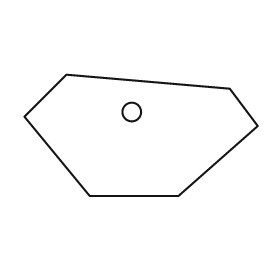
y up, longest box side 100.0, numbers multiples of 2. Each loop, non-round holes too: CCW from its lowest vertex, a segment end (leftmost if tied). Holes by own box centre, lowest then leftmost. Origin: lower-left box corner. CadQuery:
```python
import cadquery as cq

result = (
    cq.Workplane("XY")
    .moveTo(28.0, 0.0)
    .lineTo(66.0, 0.0)
    .lineTo(100.0, 30.0)
    .lineTo(88.0, 46.0)
    .lineTo(18.0, 52.0)
    .lineTo(0.0, 34.0)
    .close()
    .moveTo(46.0, 36.0)
    .circle(4.0)
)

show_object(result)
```